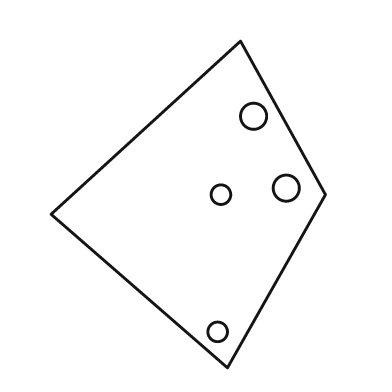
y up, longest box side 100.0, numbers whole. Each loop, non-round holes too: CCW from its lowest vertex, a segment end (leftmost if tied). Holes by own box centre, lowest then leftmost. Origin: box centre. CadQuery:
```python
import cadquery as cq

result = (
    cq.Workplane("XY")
    .moveTo(12.0, -50.0)
    .lineTo(42.0, 3.0)
    .lineTo(16.0, 50.0)
    .lineTo(-42.0, -3.0)
    .close()
    .moveTo(9.0, -39.0)
    .circle(3.0)
    .moveTo(10.0, 3.0)
    .circle(3.0)
    .moveTo(30.0, 5.0)
    .circle(4.0)
    .moveTo(20.0, 27.0)
    .circle(4.0)
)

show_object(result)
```